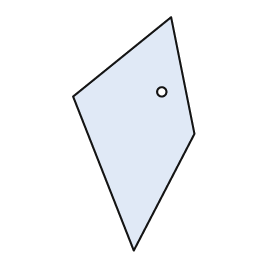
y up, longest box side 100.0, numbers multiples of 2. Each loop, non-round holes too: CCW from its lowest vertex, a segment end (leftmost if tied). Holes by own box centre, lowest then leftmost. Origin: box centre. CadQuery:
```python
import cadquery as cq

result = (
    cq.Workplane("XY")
    .moveTo(0.0, -50.0)
    .lineTo(26.0, 0.0)
    .lineTo(16.0, 50.0)
    .lineTo(-26.0, 16.0)
    .close()
    .moveTo(12.0, 18.0)
    .circle(2.0)
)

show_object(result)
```